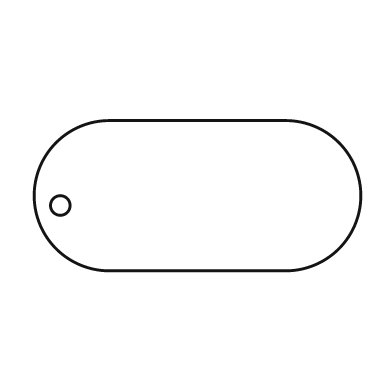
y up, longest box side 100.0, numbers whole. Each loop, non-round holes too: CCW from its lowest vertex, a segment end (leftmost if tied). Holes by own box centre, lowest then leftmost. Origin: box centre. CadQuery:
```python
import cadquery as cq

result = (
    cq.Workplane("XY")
    .moveTo(-27.0, -23.0)
    .lineTo(27.0, -23.0)
    .threePointArc((50.0, 0.0), (27.0, 23.0))
    .lineTo(-27.0, 23.0)
    .threePointArc((-50.0, 0.0), (-27.0, -23.0))
    .close()
    .moveTo(-42.0, -3.0)
    .circle(3.0)
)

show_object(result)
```